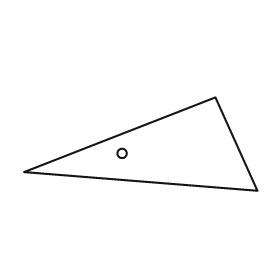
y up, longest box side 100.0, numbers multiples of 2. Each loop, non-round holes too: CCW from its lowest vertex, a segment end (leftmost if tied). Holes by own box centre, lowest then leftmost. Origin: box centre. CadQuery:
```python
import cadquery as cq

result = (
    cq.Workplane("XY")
    .moveTo(50.0, -20.0)
    .lineTo(32.0, 20.0)
    .lineTo(-50.0, -12.0)
    .close()
    .moveTo(-8.0, -4.0)
    .circle(2.0)
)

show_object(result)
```